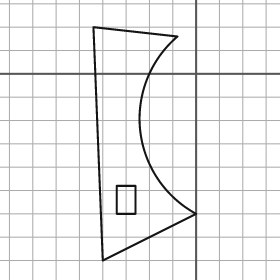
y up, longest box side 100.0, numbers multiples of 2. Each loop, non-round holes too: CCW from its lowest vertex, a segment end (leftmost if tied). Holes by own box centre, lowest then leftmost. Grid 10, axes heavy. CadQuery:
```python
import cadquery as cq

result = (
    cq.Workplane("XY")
    .moveTo(-40.0, -80.0)
    .lineTo(0.0, -60.0)
    .threePointArc((-24.0, -24.0), (-8.0, 16.0))
    .lineTo(-44.0, 20.0)
    .close()
    .moveTo(-34.0, -60.0)
    .lineTo(-26.0, -60.0)
    .lineTo(-26.0, -48.0)
    .lineTo(-34.0, -48.0)
    .close()
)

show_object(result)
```